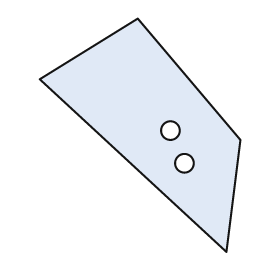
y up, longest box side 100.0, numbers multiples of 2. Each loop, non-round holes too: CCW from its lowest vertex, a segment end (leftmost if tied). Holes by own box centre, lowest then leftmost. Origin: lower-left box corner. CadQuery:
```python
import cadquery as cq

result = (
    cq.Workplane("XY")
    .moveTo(80.0, 0.0)
    .lineTo(86.0, 48.0)
    .lineTo(42.0, 100.0)
    .lineTo(0.0, 74.0)
    .close()
    .moveTo(62.0, 38.0)
    .circle(4.0)
    .moveTo(56.0, 52.0)
    .circle(4.0)
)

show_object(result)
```